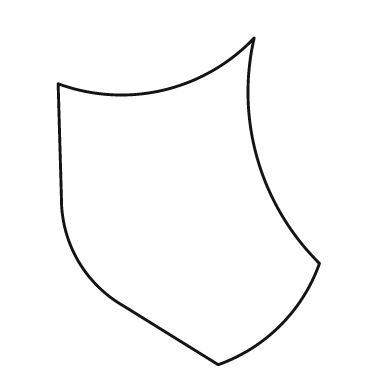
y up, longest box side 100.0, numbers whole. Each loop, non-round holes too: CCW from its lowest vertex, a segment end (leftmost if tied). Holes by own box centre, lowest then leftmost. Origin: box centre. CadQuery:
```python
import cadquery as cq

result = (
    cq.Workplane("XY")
    .moveTo(9.0, -50.0)
    .threePointArc((28.0, -38.0), (40.0, -19.0))
    .threePointArc((21.0, 13.0), (20.0, 50.0))
    .threePointArc((-8.0, 34.0), (-40.0, 36.0))
    .lineTo(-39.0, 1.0)
    .threePointArc((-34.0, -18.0), (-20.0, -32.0))
    .close()
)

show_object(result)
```